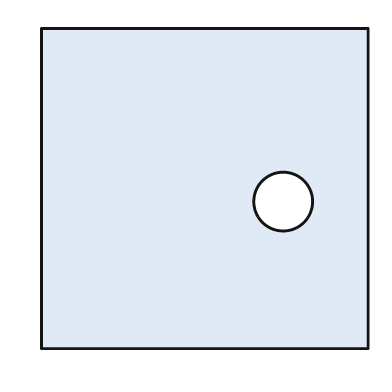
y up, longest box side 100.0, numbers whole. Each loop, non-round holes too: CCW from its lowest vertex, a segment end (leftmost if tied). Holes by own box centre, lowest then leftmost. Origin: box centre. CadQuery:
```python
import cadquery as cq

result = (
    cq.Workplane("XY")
    .moveTo(-50.0, -49.0)
    .lineTo(50.0, -49.0)
    .lineTo(50.0, 49.0)
    .lineTo(-50.0, 49.0)
    .close()
    .moveTo(24.0, -4.0)
    .circle(9.0)
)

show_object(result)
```